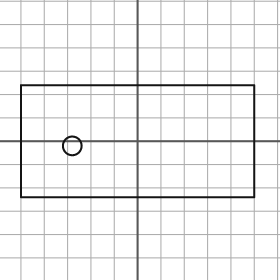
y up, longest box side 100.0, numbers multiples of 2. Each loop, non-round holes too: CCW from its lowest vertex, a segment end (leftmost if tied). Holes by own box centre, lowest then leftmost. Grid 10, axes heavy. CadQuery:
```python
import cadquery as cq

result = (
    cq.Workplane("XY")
    .moveTo(-50.0, -24.0)
    .lineTo(50.0, -24.0)
    .lineTo(50.0, 24.0)
    .lineTo(-50.0, 24.0)
    .close()
    .moveTo(-28.0, -2.0)
    .circle(4.0)
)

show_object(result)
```